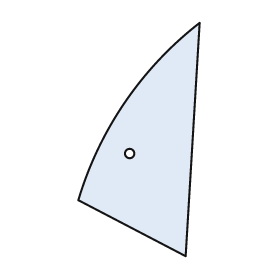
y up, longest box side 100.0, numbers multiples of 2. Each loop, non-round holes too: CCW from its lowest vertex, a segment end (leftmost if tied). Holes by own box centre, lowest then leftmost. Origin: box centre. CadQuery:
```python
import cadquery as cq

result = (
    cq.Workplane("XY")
    .moveTo(20.0, -50.0)
    .lineTo(26.0, 50.0)
    .threePointArc((-6.0, 16.0), (-26.0, -26.0))
    .close()
    .moveTo(-4.0, -6.0)
    .circle(2.0)
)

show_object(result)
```